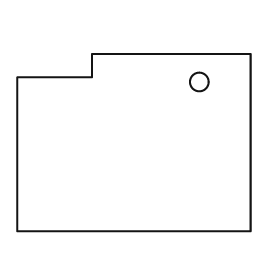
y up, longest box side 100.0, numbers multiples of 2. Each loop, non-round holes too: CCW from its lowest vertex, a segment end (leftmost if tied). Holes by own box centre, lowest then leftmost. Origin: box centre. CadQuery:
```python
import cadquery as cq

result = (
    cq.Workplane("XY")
    .moveTo(-50.0, -38.0)
    .lineTo(50.0, -38.0)
    .lineTo(50.0, 38.0)
    .lineTo(-18.0, 38.0)
    .lineTo(-18.0, 28.0)
    .lineTo(-50.0, 28.0)
    .close()
    .moveTo(28.0, 26.0)
    .circle(4.0)
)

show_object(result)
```